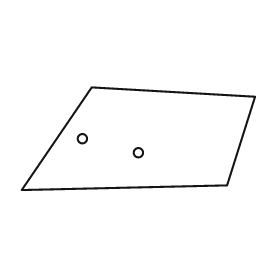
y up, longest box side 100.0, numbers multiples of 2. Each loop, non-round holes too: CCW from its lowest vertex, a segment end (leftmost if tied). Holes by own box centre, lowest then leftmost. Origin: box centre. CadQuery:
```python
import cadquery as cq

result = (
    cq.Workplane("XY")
    .moveTo(-50.0, -22.0)
    .lineTo(38.0, -20.0)
    .lineTo(50.0, 18.0)
    .lineTo(-20.0, 22.0)
    .close()
    .moveTo(0.0, -6.0)
    .circle(2.0)
    .moveTo(-24.0, 0.0)
    .circle(2.0)
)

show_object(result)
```